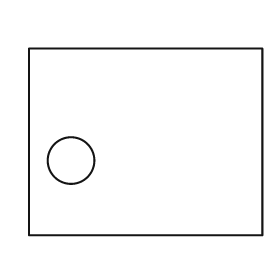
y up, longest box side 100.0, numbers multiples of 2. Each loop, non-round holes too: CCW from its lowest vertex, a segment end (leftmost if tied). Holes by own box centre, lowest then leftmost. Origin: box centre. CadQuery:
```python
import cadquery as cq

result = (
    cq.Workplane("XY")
    .moveTo(-50.0, -40.0)
    .lineTo(50.0, -40.0)
    .lineTo(50.0, 40.0)
    .lineTo(-50.0, 40.0)
    .close()
    .moveTo(-32.0, -8.0)
    .circle(10.0)
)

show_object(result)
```